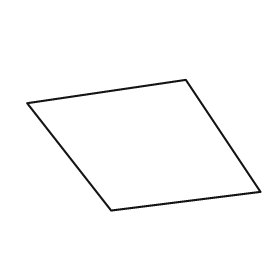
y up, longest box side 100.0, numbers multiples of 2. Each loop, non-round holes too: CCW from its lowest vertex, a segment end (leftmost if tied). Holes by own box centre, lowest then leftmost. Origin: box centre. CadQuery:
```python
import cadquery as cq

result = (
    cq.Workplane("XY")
    .moveTo(-14.0, -28.0)
    .lineTo(50.0, -20.0)
    .lineTo(18.0, 28.0)
    .lineTo(-50.0, 18.0)
    .close()
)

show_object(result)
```